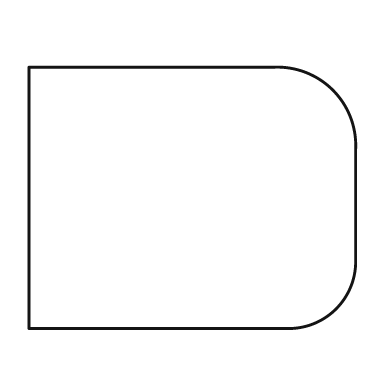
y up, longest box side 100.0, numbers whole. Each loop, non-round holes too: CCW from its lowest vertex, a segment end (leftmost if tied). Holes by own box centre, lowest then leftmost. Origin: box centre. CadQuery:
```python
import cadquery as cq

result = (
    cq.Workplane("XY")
    .moveTo(-50.0, -40.0)
    .lineTo(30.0, -40.0)
    .threePointArc((44.0, -34.0), (50.0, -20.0))
    .lineTo(50.0, 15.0)
    .threePointArc((43.0, 33.0), (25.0, 40.0))
    .lineTo(-50.0, 40.0)
    .close()
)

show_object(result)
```